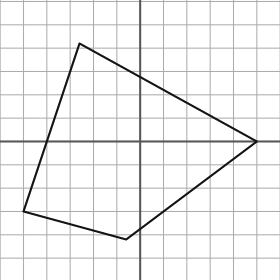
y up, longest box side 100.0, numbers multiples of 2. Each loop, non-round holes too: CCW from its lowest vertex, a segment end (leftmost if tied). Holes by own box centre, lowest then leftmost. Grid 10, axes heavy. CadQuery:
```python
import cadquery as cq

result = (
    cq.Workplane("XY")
    .moveTo(-6.0, -42.0)
    .lineTo(50.0, 0.0)
    .lineTo(-26.0, 42.0)
    .lineTo(-50.0, -30.0)
    .close()
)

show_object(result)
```